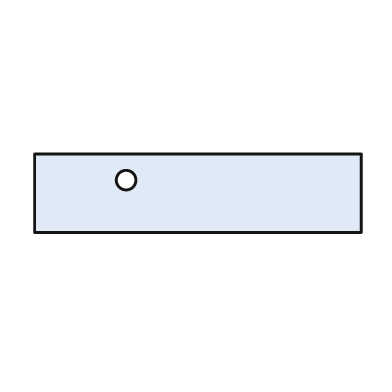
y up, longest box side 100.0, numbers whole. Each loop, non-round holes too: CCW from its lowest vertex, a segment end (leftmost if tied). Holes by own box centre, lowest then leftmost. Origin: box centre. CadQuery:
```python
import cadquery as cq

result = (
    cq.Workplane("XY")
    .moveTo(-50.0, -12.0)
    .lineTo(50.0, -12.0)
    .lineTo(50.0, 12.0)
    .lineTo(-50.0, 12.0)
    .close()
    .moveTo(-22.0, 4.0)
    .circle(3.0)
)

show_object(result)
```